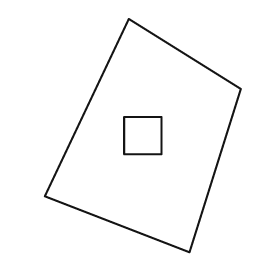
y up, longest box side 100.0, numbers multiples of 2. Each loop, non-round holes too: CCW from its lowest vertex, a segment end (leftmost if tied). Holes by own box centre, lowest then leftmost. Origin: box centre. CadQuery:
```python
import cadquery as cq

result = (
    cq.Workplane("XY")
    .moveTo(20.0, -50.0)
    .lineTo(42.0, 20.0)
    .lineTo(-6.0, 50.0)
    .lineTo(-42.0, -26.0)
    .close()
    .moveTo(-8.0, -8.0)
    .lineTo(8.0, -8.0)
    .lineTo(8.0, 8.0)
    .lineTo(-8.0, 8.0)
    .close()
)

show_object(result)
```